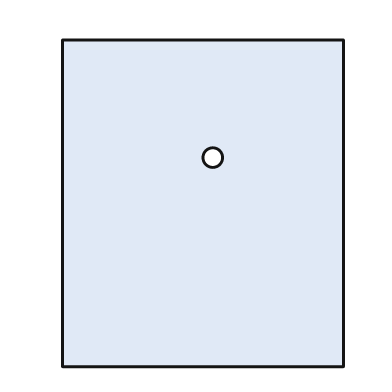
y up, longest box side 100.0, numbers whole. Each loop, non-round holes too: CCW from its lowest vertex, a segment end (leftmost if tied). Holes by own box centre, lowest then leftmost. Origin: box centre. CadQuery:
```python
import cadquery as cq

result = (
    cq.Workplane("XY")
    .moveTo(-43.0, -50.0)
    .lineTo(43.0, -50.0)
    .lineTo(43.0, 50.0)
    .lineTo(-43.0, 50.0)
    .close()
    .moveTo(3.0, 14.0)
    .circle(3.0)
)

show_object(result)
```